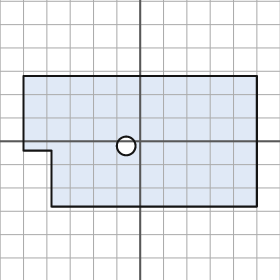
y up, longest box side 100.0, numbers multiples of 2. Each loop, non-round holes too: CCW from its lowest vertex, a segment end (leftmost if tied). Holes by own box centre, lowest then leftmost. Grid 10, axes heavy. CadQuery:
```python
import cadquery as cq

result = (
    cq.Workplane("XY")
    .moveTo(-38.0, -28.0)
    .lineTo(50.0, -28.0)
    .lineTo(50.0, 28.0)
    .lineTo(-50.0, 28.0)
    .lineTo(-50.0, -4.0)
    .lineTo(-38.0, -4.0)
    .close()
    .moveTo(-6.0, -2.0)
    .circle(4.0)
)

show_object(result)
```